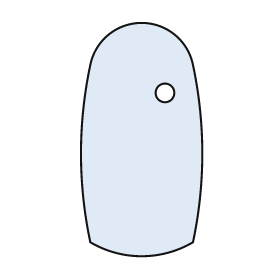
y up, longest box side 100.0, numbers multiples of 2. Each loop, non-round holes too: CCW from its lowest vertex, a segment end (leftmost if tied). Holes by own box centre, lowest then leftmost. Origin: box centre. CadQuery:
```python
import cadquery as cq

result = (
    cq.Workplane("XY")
    .moveTo(-22.0, -44.0)
    .threePointArc((0.0, -50.0), (22.0, -44.0))
    .threePointArc((26.0, -6.0), (22.0, 32.0))
    .threePointArc((0.0, 50.0), (-22.0, 32.0))
    .threePointArc((-26.0, -6.0), (-22.0, -44.0))
    .close()
    .moveTo(10.0, 20.0)
    .circle(4.0)
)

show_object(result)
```